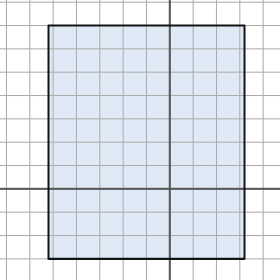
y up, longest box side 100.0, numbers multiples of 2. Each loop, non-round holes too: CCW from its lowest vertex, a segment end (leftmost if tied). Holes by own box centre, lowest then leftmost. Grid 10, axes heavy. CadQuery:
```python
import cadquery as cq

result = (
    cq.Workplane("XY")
    .moveTo(-52.0, -30.0)
    .lineTo(32.0, -30.0)
    .lineTo(32.0, 70.0)
    .lineTo(-52.0, 70.0)
    .close()
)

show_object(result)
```